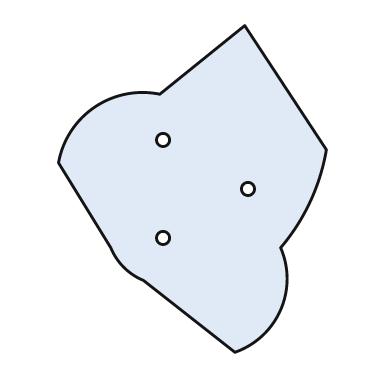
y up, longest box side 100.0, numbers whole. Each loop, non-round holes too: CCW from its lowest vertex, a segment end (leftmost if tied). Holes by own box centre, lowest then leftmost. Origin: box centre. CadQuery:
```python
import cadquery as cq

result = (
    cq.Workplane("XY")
    .moveTo(13.0, -50.0)
    .threePointArc((27.0, -37.0), (27.0, -18.0))
    .threePointArc((36.0, -4.0), (41.0, 12.0))
    .lineTo(16.0, 50.0)
    .lineTo(-10.0, 29.0)
    .threePointArc((-30.0, 25.0), (-41.0, 8.0))
    .lineTo(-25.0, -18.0)
    .threePointArc((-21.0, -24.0), (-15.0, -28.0))
    .close()
    .moveTo(-9.0, -15.0)
    .circle(2.0)
    .moveTo(17.0, 0.0)
    .circle(2.0)
    .moveTo(-9.0, 15.0)
    .circle(2.0)
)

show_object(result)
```